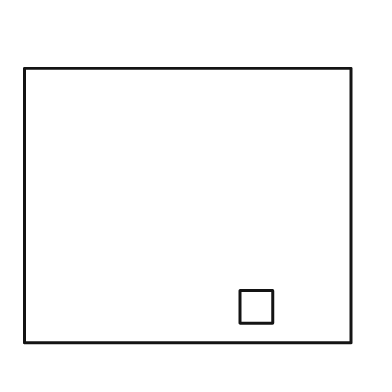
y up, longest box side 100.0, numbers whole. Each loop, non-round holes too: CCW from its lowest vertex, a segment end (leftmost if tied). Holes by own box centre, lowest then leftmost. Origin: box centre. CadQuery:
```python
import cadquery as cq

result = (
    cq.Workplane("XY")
    .moveTo(-50.0, -42.0)
    .lineTo(50.0, -42.0)
    .lineTo(50.0, 42.0)
    .lineTo(-50.0, 42.0)
    .close()
    .moveTo(16.0, -36.0)
    .lineTo(26.0, -36.0)
    .lineTo(26.0, -26.0)
    .lineTo(16.0, -26.0)
    .close()
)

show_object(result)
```